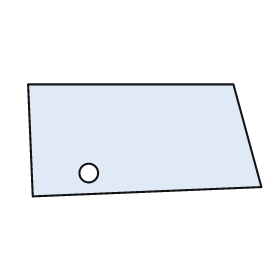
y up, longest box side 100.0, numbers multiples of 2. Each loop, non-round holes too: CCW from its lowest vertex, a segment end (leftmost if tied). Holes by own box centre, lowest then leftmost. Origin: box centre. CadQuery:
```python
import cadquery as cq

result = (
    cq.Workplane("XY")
    .moveTo(-48.0, -24.0)
    .lineTo(50.0, -20.0)
    .lineTo(38.0, 24.0)
    .lineTo(-50.0, 24.0)
    .close()
    .moveTo(-24.0, -14.0)
    .circle(4.0)
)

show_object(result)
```